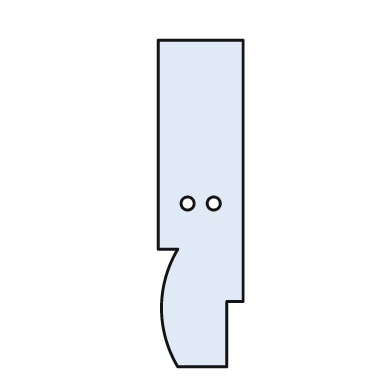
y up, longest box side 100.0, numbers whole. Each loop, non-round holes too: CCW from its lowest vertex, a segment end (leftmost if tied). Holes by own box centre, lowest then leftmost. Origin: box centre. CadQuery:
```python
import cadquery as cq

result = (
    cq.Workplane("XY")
    .moveTo(-7.0, -50.0)
    .lineTo(8.0, -50.0)
    .lineTo(8.0, -30.0)
    .lineTo(13.0, -30.0)
    .lineTo(13.0, 50.0)
    .lineTo(-13.0, 50.0)
    .lineTo(-13.0, -14.0)
    .lineTo(-7.0, -14.0)
    .threePointArc((-12.0, -32.0), (-7.0, -50.0))
    .close()
    .moveTo(-4.0, 0.0)
    .circle(2.0)
    .moveTo(4.0, 0.0)
    .circle(2.0)
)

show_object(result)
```